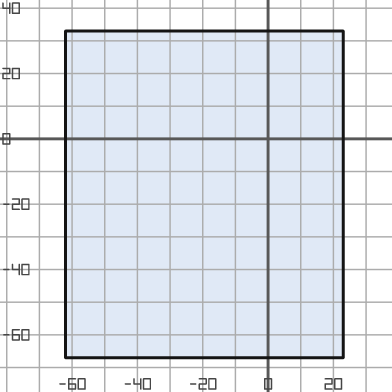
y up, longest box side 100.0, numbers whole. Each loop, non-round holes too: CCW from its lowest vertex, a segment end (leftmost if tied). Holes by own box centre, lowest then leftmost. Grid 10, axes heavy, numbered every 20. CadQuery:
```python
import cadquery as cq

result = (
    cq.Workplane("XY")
    .moveTo(-62.0, -67.0)
    .lineTo(23.0, -67.0)
    .lineTo(23.0, 33.0)
    .lineTo(-62.0, 33.0)
    .close()
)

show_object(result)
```